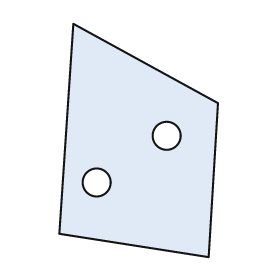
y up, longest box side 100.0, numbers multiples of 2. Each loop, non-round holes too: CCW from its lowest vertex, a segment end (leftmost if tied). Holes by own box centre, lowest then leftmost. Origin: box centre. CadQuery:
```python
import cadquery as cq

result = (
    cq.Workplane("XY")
    .moveTo(30.0, -50.0)
    .lineTo(34.0, 16.0)
    .lineTo(-28.0, 50.0)
    .lineTo(-34.0, -40.0)
    .close()
    .moveTo(-18.0, -18.0)
    .circle(6.0)
    .moveTo(12.0, 2.0)
    .circle(6.0)
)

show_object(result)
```